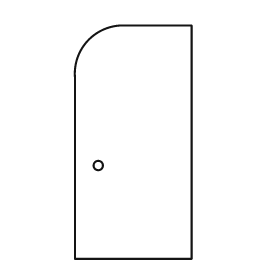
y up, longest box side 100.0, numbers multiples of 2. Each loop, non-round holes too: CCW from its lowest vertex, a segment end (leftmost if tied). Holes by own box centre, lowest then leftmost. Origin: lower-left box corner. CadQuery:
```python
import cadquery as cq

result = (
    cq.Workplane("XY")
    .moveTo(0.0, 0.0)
    .lineTo(50.0, 0.0)
    .lineTo(50.0, 100.0)
    .lineTo(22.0, 100.0)
    .threePointArc((6.0, 94.0), (0.0, 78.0))
    .close()
    .moveTo(10.0, 40.0)
    .circle(2.0)
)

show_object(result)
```